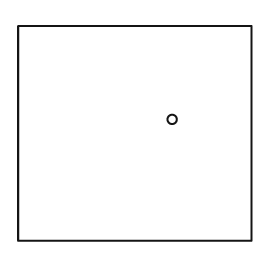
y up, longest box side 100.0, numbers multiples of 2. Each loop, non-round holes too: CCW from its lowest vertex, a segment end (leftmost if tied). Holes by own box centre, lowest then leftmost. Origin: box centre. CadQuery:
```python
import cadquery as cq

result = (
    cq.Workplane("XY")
    .moveTo(-50.0, -46.0)
    .lineTo(50.0, -46.0)
    .lineTo(50.0, 46.0)
    .lineTo(-50.0, 46.0)
    .close()
    .moveTo(16.0, 6.0)
    .circle(2.0)
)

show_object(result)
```